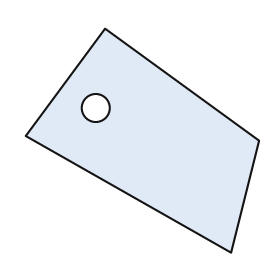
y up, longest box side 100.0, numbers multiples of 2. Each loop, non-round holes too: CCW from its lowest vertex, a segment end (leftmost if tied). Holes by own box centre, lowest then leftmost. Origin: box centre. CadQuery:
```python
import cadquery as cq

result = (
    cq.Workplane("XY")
    .moveTo(38.0, -48.0)
    .lineTo(50.0, 0.0)
    .lineTo(-16.0, 48.0)
    .lineTo(-50.0, 2.0)
    .close()
    .moveTo(-20.0, 14.0)
    .circle(6.0)
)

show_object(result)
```